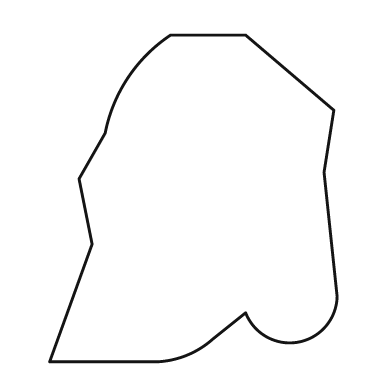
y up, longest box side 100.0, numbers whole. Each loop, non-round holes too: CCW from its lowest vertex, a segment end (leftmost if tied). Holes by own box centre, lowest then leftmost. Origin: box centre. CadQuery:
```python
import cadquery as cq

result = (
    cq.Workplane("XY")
    .moveTo(-44.0, -50.0)
    .lineTo(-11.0, -50.0)
    .threePointArc((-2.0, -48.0), (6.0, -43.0))
    .lineTo(16.0, -35.0)
    .threePointArc((32.0, -44.0), (44.0, -30.0))
    .lineTo(40.0, 8.0)
    .lineTo(43.0, 27.0)
    .lineTo(16.0, 50.0)
    .lineTo(-7.0, 50.0)
    .threePointArc((-20.0, 37.0), (-27.0, 20.0))
    .lineTo(-35.0, 6.0)
    .lineTo(-31.0, -14.0)
    .close()
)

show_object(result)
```